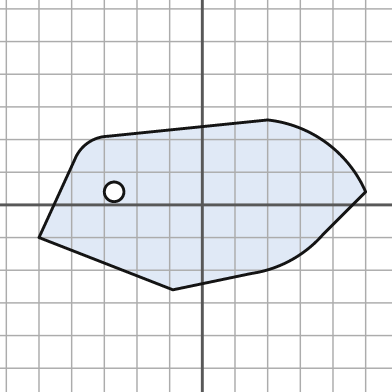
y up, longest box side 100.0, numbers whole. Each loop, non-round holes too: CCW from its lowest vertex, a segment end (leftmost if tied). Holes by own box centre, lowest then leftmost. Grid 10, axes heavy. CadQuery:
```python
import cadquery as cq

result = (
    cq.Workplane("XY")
    .moveTo(-9.0, -26.0)
    .lineTo(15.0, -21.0)
    .threePointArc((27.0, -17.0), (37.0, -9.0))
    .lineTo(50.0, 4.0)
    .threePointArc((38.0, 19.0), (20.0, 26.0))
    .lineTo(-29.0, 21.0)
    .threePointArc((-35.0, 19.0), (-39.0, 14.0))
    .lineTo(-50.0, -10.0)
    .close()
    .moveTo(-27.0, 4.0)
    .circle(3.0)
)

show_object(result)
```